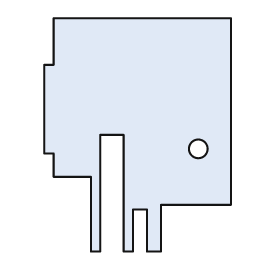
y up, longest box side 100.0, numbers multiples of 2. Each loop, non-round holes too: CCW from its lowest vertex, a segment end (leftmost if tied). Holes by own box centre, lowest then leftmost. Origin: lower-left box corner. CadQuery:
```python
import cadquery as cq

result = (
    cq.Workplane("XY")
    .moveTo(20.0, 0.0)
    .lineTo(24.0, 0.0)
    .lineTo(24.0, 50.0)
    .lineTo(34.0, 50.0)
    .lineTo(34.0, 0.0)
    .lineTo(38.0, 0.0)
    .lineTo(38.0, 18.0)
    .lineTo(44.0, 18.0)
    .lineTo(44.0, 0.0)
    .lineTo(50.0, 0.0)
    .lineTo(50.0, 20.0)
    .lineTo(80.0, 20.0)
    .lineTo(80.0, 100.0)
    .lineTo(4.0, 100.0)
    .lineTo(4.0, 80.0)
    .lineTo(0.0, 80.0)
    .lineTo(0.0, 42.0)
    .lineTo(4.0, 42.0)
    .lineTo(4.0, 32.0)
    .lineTo(20.0, 32.0)
    .close()
    .moveTo(66.0, 44.0)
    .circle(4.0)
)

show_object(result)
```